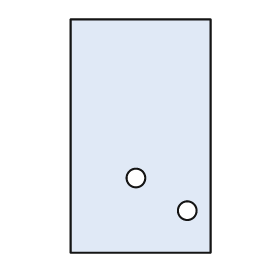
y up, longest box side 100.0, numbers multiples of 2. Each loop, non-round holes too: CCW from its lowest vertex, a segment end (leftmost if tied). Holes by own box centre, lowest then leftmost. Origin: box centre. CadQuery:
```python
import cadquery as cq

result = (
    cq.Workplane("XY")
    .moveTo(-30.0, -50.0)
    .lineTo(30.0, -50.0)
    .lineTo(30.0, 50.0)
    .lineTo(-30.0, 50.0)
    .close()
    .moveTo(20.0, -32.0)
    .circle(4.0)
    .moveTo(-2.0, -18.0)
    .circle(4.0)
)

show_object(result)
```